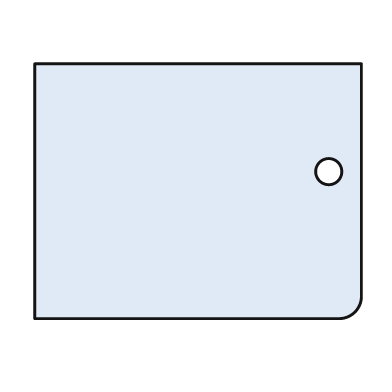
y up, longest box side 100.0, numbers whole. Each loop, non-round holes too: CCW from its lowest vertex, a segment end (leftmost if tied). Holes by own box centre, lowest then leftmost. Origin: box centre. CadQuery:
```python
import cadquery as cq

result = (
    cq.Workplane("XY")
    .moveTo(-50.0, -39.0)
    .lineTo(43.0, -39.0)
    .threePointArc((48.0, -37.0), (50.0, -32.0))
    .lineTo(50.0, 39.0)
    .lineTo(-50.0, 39.0)
    .close()
    .moveTo(40.0, 6.0)
    .circle(4.0)
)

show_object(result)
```